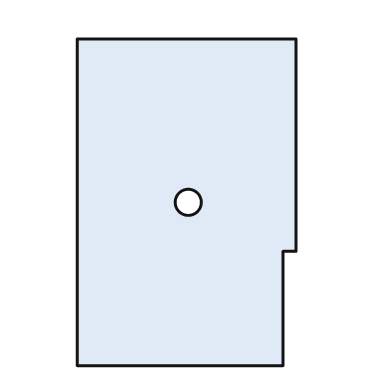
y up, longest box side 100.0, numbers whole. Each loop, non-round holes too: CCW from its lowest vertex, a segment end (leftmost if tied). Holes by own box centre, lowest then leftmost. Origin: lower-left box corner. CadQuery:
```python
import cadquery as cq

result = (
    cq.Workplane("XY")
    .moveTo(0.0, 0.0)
    .lineTo(63.0, 0.0)
    .lineTo(63.0, 35.0)
    .lineTo(67.0, 35.0)
    .lineTo(67.0, 100.0)
    .lineTo(0.0, 100.0)
    .close()
    .moveTo(34.0, 50.0)
    .circle(4.0)
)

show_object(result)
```